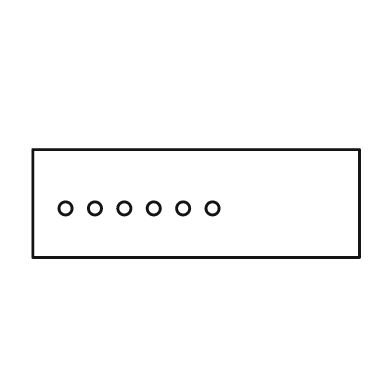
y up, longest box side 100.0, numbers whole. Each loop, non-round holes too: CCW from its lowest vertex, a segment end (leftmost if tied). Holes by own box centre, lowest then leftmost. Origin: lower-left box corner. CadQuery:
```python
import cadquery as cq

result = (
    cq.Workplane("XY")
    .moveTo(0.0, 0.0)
    .lineTo(100.0, 0.0)
    .lineTo(100.0, 33.0)
    .lineTo(0.0, 33.0)
    .close()
    .moveTo(10.0, 15.0)
    .circle(2.0)
    .moveTo(19.0, 15.0)
    .circle(2.0)
    .moveTo(28.0, 15.0)
    .circle(2.0)
    .moveTo(37.0, 15.0)
    .circle(2.0)
    .moveTo(46.0, 15.0)
    .circle(2.0)
    .moveTo(55.0, 15.0)
    .circle(2.0)
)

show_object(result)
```